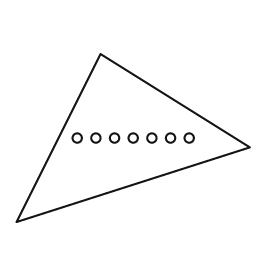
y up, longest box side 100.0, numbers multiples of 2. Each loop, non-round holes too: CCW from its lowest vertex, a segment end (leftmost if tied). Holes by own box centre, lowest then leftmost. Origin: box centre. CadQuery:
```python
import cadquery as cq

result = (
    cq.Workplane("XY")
    .moveTo(-50.0, -36.0)
    .lineTo(50.0, -4.0)
    .lineTo(-14.0, 36.0)
    .close()
    .moveTo(-24.0, 0.0)
    .circle(2.0)
    .moveTo(-16.0, 0.0)
    .circle(2.0)
    .moveTo(-8.0, 0.0)
    .circle(2.0)
    .moveTo(0.0, 0.0)
    .circle(2.0)
    .moveTo(8.0, 0.0)
    .circle(2.0)
    .moveTo(16.0, 0.0)
    .circle(2.0)
    .moveTo(24.0, 0.0)
    .circle(2.0)
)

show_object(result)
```